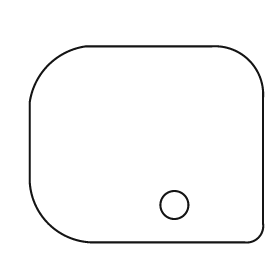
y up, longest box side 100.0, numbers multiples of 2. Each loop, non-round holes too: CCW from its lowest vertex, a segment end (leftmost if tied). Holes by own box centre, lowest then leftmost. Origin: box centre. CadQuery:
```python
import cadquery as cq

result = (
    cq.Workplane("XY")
    .moveTo(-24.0, -42.0)
    .lineTo(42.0, -42.0)
    .threePointArc((48.0, -40.0), (50.0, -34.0))
    .lineTo(50.0, 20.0)
    .threePointArc((44.0, 36.0), (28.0, 42.0))
    .lineTo(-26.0, 42.0)
    .threePointArc((-42.0, 34.0), (-50.0, 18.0))
    .lineTo(-50.0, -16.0)
    .threePointArc((-42.0, -34.0), (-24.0, -42.0))
    .close()
    .moveTo(12.0, -26.0)
    .circle(6.0)
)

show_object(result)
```